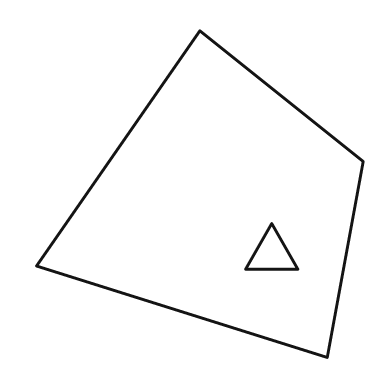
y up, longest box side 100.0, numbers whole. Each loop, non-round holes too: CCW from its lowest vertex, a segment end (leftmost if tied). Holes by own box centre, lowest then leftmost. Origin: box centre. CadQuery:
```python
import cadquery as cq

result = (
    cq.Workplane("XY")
    .moveTo(39.0, -50.0)
    .lineTo(50.0, 10.0)
    .lineTo(0.0, 50.0)
    .lineTo(-50.0, -22.0)
    .close()
    .moveTo(14.0, -23.0)
    .lineTo(30.0, -23.0)
    .lineTo(22.0, -9.0)
    .close()
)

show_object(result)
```